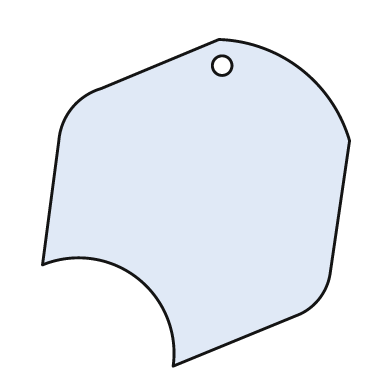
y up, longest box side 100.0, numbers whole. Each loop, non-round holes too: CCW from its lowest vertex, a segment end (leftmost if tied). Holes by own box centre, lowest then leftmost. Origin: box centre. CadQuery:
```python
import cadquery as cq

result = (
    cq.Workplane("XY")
    .moveTo(-7.0, -50.0)
    .lineTo(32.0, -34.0)
    .threePointArc((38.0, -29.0), (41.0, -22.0))
    .lineTo(47.0, 19.0)
    .threePointArc((32.0, 41.0), (7.0, 50.0))
    .lineTo(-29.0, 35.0)
    .threePointArc((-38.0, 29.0), (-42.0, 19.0))
    .lineTo(-47.0, -19.0)
    .threePointArc((-18.0, -23.0), (-7.0, -50.0))
    .close()
    .moveTo(8.0, 42.0)
    .circle(3.0)
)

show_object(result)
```